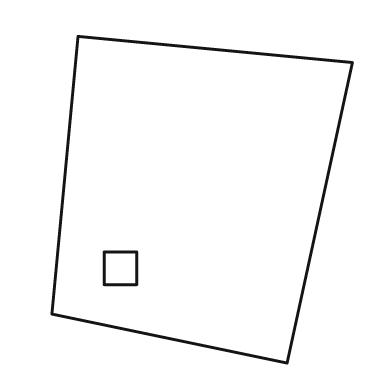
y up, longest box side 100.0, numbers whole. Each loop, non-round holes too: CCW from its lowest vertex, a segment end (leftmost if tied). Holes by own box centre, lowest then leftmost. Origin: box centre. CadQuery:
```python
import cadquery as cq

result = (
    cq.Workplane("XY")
    .moveTo(26.0, -50.0)
    .lineTo(46.0, 42.0)
    .lineTo(-38.0, 50.0)
    .lineTo(-46.0, -35.0)
    .close()
    .moveTo(-30.0, -26.0)
    .lineTo(-20.0, -26.0)
    .lineTo(-20.0, -16.0)
    .lineTo(-30.0, -16.0)
    .close()
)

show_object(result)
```